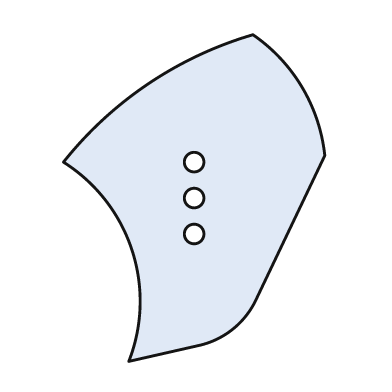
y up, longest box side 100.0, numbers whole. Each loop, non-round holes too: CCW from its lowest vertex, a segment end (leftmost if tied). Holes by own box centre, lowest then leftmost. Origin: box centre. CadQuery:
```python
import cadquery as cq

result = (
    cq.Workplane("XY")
    .moveTo(-20.0, -50.0)
    .lineTo(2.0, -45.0)
    .threePointArc((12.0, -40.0), (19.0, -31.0))
    .lineTo(40.0, 13.0)
    .threePointArc((33.0, 34.0), (18.0, 50.0))
    .threePointArc((-14.0, 35.0), (-40.0, 11.0))
    .threePointArc((-19.0, -16.0), (-20.0, -50.0))
    .close()
    .moveTo(0.0, -11.0)
    .circle(3.0)
    .moveTo(0.0, 0.0)
    .circle(3.0)
    .moveTo(0.0, 11.0)
    .circle(3.0)
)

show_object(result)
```